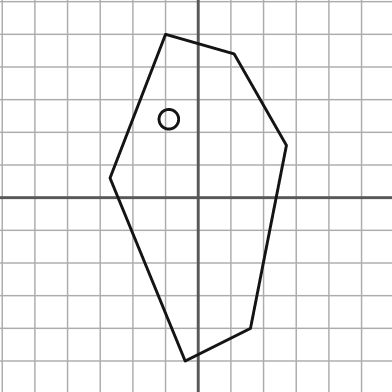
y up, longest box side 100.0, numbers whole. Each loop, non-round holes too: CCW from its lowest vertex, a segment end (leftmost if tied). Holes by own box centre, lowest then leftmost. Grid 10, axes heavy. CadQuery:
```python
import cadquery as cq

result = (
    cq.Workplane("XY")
    .moveTo(-4.0, -50.0)
    .lineTo(16.0, -40.0)
    .lineTo(27.0, 16.0)
    .lineTo(11.0, 44.0)
    .lineTo(-10.0, 50.0)
    .lineTo(-27.0, 6.0)
    .close()
    .moveTo(-9.0, 24.0)
    .circle(3.0)
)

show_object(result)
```